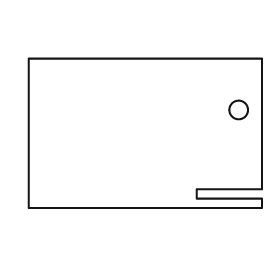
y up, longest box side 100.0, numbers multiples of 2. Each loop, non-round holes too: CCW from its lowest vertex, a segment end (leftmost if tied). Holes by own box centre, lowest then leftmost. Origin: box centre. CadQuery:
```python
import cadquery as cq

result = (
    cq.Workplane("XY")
    .moveTo(-50.0, -32.0)
    .lineTo(50.0, -32.0)
    .lineTo(50.0, -28.0)
    .lineTo(22.0, -28.0)
    .lineTo(22.0, -24.0)
    .lineTo(50.0, -24.0)
    .lineTo(50.0, 32.0)
    .lineTo(-50.0, 32.0)
    .close()
    .moveTo(40.0, 10.0)
    .circle(4.0)
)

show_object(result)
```